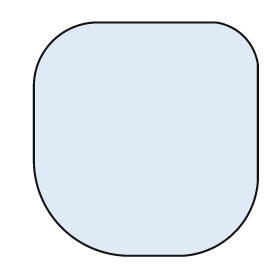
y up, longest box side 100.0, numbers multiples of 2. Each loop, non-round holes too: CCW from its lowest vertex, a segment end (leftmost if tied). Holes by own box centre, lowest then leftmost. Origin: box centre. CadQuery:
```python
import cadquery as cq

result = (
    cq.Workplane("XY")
    .moveTo(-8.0, -50.0)
    .lineTo(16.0, -50.0)
    .threePointArc((38.0, -40.0), (48.0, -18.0))
    .lineTo(48.0, 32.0)
    .threePointArc((42.0, 44.0), (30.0, 50.0))
    .lineTo(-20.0, 50.0)
    .threePointArc((-40.0, 42.0), (-48.0, 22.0))
    .lineTo(-48.0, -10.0)
    .threePointArc((-36.0, -38.0), (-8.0, -50.0))
    .close()
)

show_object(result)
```